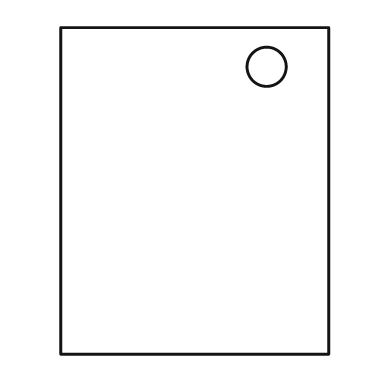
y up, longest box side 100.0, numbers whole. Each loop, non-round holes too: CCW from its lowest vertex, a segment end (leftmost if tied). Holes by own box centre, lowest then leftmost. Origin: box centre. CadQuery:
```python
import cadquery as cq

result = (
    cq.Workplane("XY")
    .moveTo(-41.0, -50.0)
    .lineTo(41.0, -50.0)
    .lineTo(41.0, 50.0)
    .lineTo(-41.0, 50.0)
    .close()
    .moveTo(22.0, 38.0)
    .circle(6.0)
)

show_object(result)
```